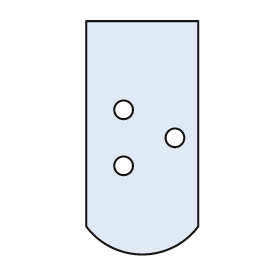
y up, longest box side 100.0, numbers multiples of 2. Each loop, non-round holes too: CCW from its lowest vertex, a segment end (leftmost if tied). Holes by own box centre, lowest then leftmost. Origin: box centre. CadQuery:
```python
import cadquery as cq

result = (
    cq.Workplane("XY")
    .moveTo(-24.0, -38.0)
    .threePointArc((0.0, -50.0), (24.0, -38.0))
    .lineTo(24.0, 50.0)
    .lineTo(-24.0, 50.0)
    .close()
    .moveTo(-8.0, -12.0)
    .circle(4.0)
    .moveTo(14.0, 0.0)
    .circle(4.0)
    .moveTo(-8.0, 12.0)
    .circle(4.0)
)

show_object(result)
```